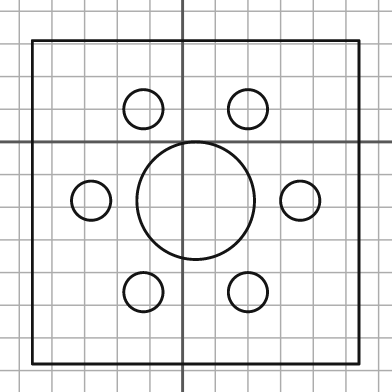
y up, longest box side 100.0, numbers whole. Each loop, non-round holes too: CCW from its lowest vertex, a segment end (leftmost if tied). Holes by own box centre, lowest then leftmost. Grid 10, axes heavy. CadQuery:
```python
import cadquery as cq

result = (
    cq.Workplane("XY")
    .moveTo(-46.0, -68.0)
    .lineTo(54.0, -68.0)
    .lineTo(54.0, 31.0)
    .lineTo(-46.0, 31.0)
    .close()
    .moveTo(-12.0, -46.0)
    .circle(6.0)
    .moveTo(20.0, -46.0)
    .circle(6.0)
    .moveTo(-28.0, -18.0)
    .circle(6.0)
    .moveTo(4.0, -18.0)
    .circle(18.0)
    .moveTo(36.0, -18.0)
    .circle(6.0)
    .moveTo(-12.0, 10.0)
    .circle(6.0)
    .moveTo(20.0, 10.0)
    .circle(6.0)
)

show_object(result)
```